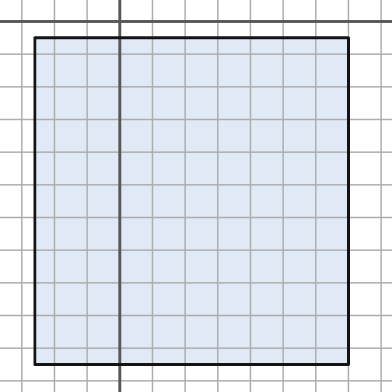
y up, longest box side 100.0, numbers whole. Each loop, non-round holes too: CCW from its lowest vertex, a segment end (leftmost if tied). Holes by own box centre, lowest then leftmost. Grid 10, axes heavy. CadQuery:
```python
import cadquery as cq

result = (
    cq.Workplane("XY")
    .moveTo(-26.0, -105.0)
    .lineTo(70.0, -105.0)
    .lineTo(70.0, -5.0)
    .lineTo(-26.0, -5.0)
    .close()
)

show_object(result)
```